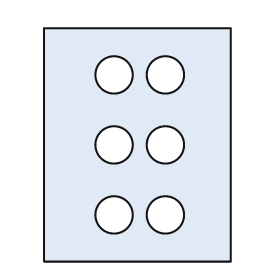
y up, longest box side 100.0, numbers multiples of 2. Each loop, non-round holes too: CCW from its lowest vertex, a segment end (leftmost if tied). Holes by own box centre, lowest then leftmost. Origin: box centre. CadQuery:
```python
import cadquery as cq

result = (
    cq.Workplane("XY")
    .moveTo(-40.0, -50.0)
    .lineTo(40.0, -50.0)
    .lineTo(40.0, 50.0)
    .lineTo(-40.0, 50.0)
    .close()
    .moveTo(-10.0, -30.0)
    .circle(8.0)
    .moveTo(12.0, -30.0)
    .circle(8.0)
    .moveTo(-10.0, 0.0)
    .circle(8.0)
    .moveTo(12.0, 0.0)
    .circle(8.0)
    .moveTo(-10.0, 30.0)
    .circle(8.0)
    .moveTo(12.0, 30.0)
    .circle(8.0)
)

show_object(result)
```